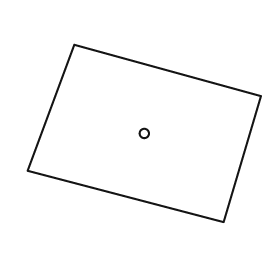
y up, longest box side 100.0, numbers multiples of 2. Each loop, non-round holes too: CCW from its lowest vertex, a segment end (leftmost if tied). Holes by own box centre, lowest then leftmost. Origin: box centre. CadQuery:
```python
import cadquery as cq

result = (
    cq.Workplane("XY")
    .moveTo(34.0, -38.0)
    .lineTo(50.0, 16.0)
    .lineTo(-30.0, 38.0)
    .lineTo(-50.0, -16.0)
    .close()
    .moveTo(0.0, 0.0)
    .circle(2.0)
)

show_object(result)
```